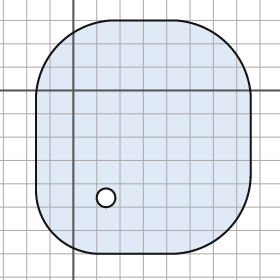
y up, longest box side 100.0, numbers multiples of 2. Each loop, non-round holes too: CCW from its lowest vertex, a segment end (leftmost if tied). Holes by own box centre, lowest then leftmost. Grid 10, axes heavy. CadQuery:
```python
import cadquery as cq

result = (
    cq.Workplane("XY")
    .moveTo(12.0, -70.0)
    .lineTo(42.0, -70.0)
    .threePointArc((66.0, -60.0), (76.0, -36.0))
    .lineTo(76.0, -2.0)
    .threePointArc((66.0, 20.0), (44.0, 30.0))
    .lineTo(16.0, 30.0)
    .threePointArc((-6.0, 20.0), (-16.0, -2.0))
    .lineTo(-16.0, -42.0)
    .threePointArc((-8.0, -62.0), (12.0, -70.0))
    .close()
    .moveTo(14.0, -46.0)
    .circle(4.0)
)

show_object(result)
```